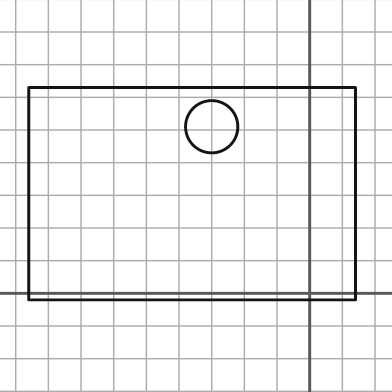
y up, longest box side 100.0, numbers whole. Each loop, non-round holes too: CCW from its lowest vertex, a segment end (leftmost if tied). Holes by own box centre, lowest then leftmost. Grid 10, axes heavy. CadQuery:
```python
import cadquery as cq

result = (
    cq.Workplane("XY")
    .moveTo(-86.0, -2.0)
    .lineTo(14.0, -2.0)
    .lineTo(14.0, 63.0)
    .lineTo(-86.0, 63.0)
    .close()
    .moveTo(-30.0, 51.0)
    .circle(8.0)
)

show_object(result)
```